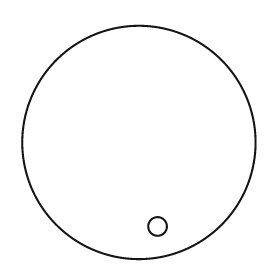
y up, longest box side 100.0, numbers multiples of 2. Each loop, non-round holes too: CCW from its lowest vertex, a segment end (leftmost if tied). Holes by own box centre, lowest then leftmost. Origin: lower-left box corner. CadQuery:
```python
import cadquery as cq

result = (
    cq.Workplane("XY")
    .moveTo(50.0, 50.0)
    .circle(50.0)
    .moveTo(58.0, 14.0)
    .circle(4.0)
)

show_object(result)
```